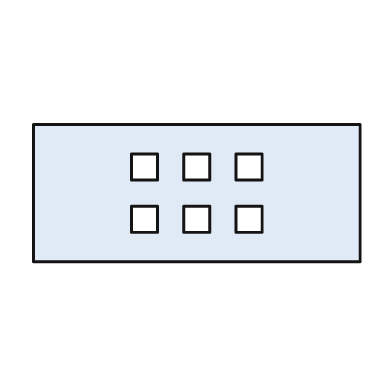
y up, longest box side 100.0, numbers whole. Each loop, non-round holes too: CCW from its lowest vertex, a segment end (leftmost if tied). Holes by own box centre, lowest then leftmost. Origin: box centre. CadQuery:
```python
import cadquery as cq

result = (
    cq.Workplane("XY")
    .moveTo(-50.0, -21.0)
    .lineTo(50.0, -21.0)
    .lineTo(50.0, 21.0)
    .lineTo(-50.0, 21.0)
    .close()
    .moveTo(-20.0, -12.0)
    .lineTo(-12.0, -12.0)
    .lineTo(-12.0, -4.0)
    .lineTo(-20.0, -4.0)
    .close()
    .moveTo(-4.0, -12.0)
    .lineTo(4.0, -12.0)
    .lineTo(4.0, -4.0)
    .lineTo(-4.0, -4.0)
    .close()
    .moveTo(12.0, -12.0)
    .lineTo(20.0, -12.0)
    .lineTo(20.0, -4.0)
    .lineTo(12.0, -4.0)
    .close()
    .moveTo(-20.0, 4.0)
    .lineTo(-12.0, 4.0)
    .lineTo(-12.0, 12.0)
    .lineTo(-20.0, 12.0)
    .close()
    .moveTo(-4.0, 4.0)
    .lineTo(4.0, 4.0)
    .lineTo(4.0, 12.0)
    .lineTo(-4.0, 12.0)
    .close()
    .moveTo(12.0, 4.0)
    .lineTo(20.0, 4.0)
    .lineTo(20.0, 12.0)
    .lineTo(12.0, 12.0)
    .close()
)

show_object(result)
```